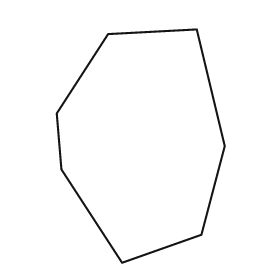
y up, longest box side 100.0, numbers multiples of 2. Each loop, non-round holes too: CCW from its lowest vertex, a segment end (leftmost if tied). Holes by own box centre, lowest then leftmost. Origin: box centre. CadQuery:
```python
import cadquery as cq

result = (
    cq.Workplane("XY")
    .moveTo(-8.0, -50.0)
    .lineTo(26.0, -38.0)
    .lineTo(36.0, 0.0)
    .lineTo(24.0, 50.0)
    .lineTo(-14.0, 48.0)
    .lineTo(-36.0, 14.0)
    .lineTo(-34.0, -10.0)
    .close()
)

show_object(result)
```